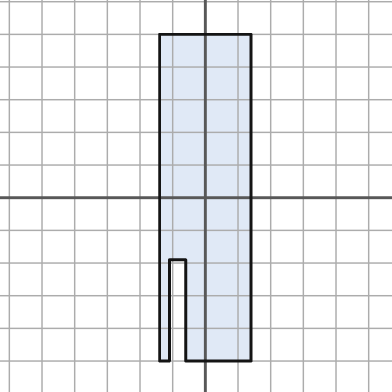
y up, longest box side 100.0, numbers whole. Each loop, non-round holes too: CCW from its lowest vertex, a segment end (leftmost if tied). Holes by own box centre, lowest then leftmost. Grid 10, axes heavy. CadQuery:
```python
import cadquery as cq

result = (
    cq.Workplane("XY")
    .moveTo(-14.0, -50.0)
    .lineTo(-11.0, -50.0)
    .lineTo(-11.0, -19.0)
    .lineTo(-6.0, -19.0)
    .lineTo(-6.0, -50.0)
    .lineTo(14.0, -50.0)
    .lineTo(14.0, 50.0)
    .lineTo(-14.0, 50.0)
    .close()
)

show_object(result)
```